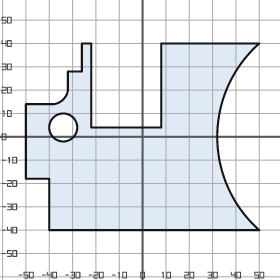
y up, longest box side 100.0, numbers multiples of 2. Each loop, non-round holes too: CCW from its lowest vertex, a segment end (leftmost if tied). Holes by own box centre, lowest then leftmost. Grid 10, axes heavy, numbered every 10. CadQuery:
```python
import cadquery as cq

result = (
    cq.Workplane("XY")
    .moveTo(-40.0, -40.0)
    .lineTo(50.0, -40.0)
    .threePointArc((32.0, 0.0), (50.0, 40.0))
    .lineTo(8.0, 40.0)
    .lineTo(8.0, 4.0)
    .lineTo(-22.0, 4.0)
    .lineTo(-22.0, 40.0)
    .lineTo(-26.0, 40.0)
    .lineTo(-26.0, 28.0)
    .lineTo(-32.0, 28.0)
    .lineTo(-32.0, 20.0)
    .threePointArc((-34.0, 16.0), (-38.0, 14.0))
    .lineTo(-50.0, 14.0)
    .lineTo(-50.0, -18.0)
    .lineTo(-40.0, -18.0)
    .close()
    .moveTo(-34.0, 4.0)
    .circle(6.0)
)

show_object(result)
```